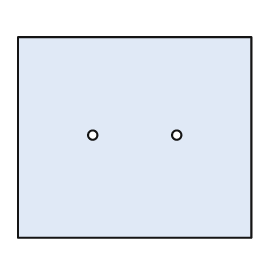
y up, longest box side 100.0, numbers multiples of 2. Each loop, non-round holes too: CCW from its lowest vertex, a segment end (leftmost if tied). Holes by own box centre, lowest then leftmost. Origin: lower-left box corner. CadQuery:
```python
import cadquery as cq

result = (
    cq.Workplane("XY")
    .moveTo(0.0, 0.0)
    .lineTo(100.0, 0.0)
    .lineTo(100.0, 86.0)
    .lineTo(0.0, 86.0)
    .close()
    .moveTo(32.0, 44.0)
    .circle(2.0)
    .moveTo(68.0, 44.0)
    .circle(2.0)
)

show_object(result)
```